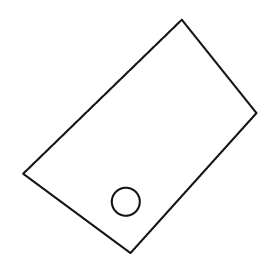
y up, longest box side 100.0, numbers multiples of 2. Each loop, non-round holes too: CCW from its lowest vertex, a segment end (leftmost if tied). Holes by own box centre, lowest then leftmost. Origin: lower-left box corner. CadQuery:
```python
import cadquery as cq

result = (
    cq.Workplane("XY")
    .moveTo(46.0, 0.0)
    .lineTo(100.0, 60.0)
    .lineTo(68.0, 100.0)
    .lineTo(0.0, 34.0)
    .close()
    .moveTo(44.0, 22.0)
    .circle(6.0)
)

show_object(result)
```